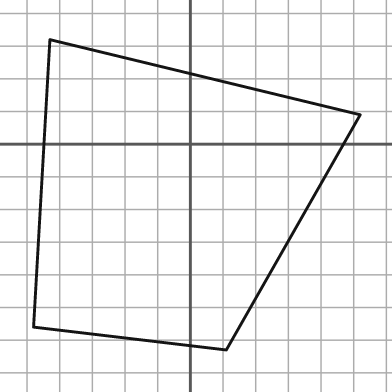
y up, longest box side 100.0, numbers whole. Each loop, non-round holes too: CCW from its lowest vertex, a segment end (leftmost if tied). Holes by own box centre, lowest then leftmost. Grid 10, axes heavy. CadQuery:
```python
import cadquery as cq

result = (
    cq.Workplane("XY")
    .moveTo(11.0, -63.0)
    .lineTo(52.0, 9.0)
    .lineTo(-43.0, 32.0)
    .lineTo(-48.0, -56.0)
    .close()
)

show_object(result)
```